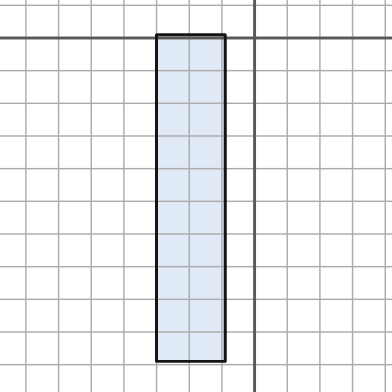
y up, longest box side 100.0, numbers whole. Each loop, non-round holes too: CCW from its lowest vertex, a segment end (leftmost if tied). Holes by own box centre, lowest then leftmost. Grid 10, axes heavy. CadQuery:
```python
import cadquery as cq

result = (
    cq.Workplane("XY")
    .moveTo(-30.0, -99.0)
    .lineTo(-9.0, -99.0)
    .lineTo(-9.0, 1.0)
    .lineTo(-30.0, 1.0)
    .close()
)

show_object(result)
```